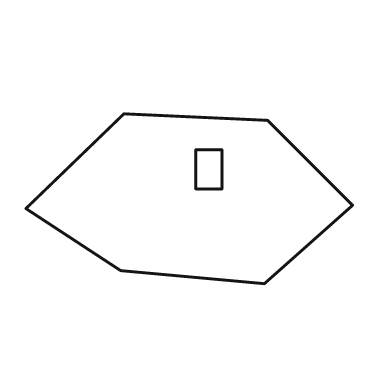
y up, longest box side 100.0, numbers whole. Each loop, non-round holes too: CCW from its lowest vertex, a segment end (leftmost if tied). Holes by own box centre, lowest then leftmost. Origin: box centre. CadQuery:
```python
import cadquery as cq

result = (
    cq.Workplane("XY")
    .moveTo(23.0, -26.0)
    .lineTo(50.0, -2.0)
    .lineTo(24.0, 24.0)
    .lineTo(-20.0, 26.0)
    .lineTo(-50.0, -3.0)
    .lineTo(-21.0, -22.0)
    .close()
    .moveTo(2.0, 3.0)
    .lineTo(10.0, 3.0)
    .lineTo(10.0, 15.0)
    .lineTo(2.0, 15.0)
    .close()
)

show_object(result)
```